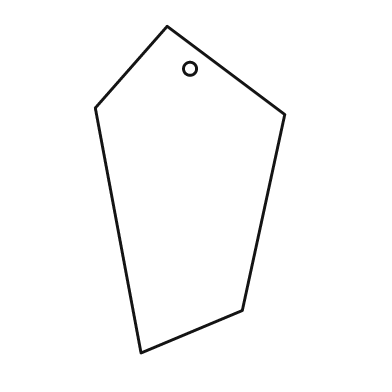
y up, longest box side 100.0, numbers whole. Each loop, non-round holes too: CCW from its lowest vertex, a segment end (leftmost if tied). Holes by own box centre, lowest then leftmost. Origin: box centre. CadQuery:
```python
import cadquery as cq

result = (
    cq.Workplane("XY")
    .moveTo(-15.0, -50.0)
    .lineTo(16.0, -37.0)
    .lineTo(29.0, 23.0)
    .lineTo(-7.0, 50.0)
    .lineTo(-29.0, 25.0)
    .close()
    .moveTo(0.0, 37.0)
    .circle(2.0)
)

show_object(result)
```